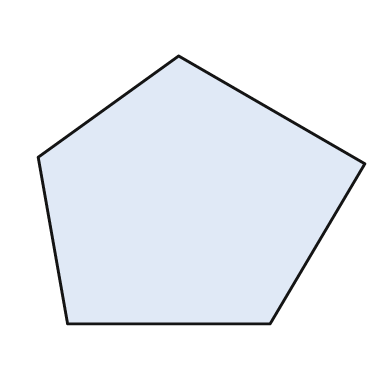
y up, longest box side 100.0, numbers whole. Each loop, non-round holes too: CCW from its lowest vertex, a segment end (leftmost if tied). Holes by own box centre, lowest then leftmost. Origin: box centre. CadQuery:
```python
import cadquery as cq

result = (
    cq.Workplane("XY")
    .moveTo(-41.0, -41.0)
    .lineTo(21.0, -41.0)
    .lineTo(50.0, 8.0)
    .lineTo(-7.0, 41.0)
    .lineTo(-50.0, 10.0)
    .close()
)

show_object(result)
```